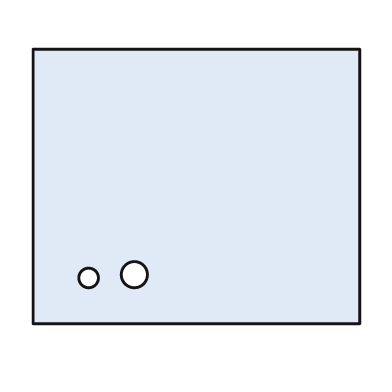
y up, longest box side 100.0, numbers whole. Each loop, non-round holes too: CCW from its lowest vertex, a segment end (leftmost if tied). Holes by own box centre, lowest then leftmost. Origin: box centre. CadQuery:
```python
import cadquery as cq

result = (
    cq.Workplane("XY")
    .moveTo(-50.0, -42.0)
    .lineTo(50.0, -42.0)
    .lineTo(50.0, 42.0)
    .lineTo(-50.0, 42.0)
    .close()
    .moveTo(-33.0, -28.0)
    .circle(3.0)
    .moveTo(-19.0, -27.0)
    .circle(4.0)
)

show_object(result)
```